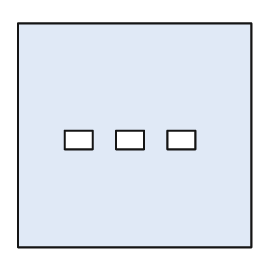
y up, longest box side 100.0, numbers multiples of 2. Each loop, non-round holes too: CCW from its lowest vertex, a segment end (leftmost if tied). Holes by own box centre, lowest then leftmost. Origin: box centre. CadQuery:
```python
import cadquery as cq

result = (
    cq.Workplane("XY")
    .moveTo(-50.0, -48.0)
    .lineTo(50.0, -48.0)
    .lineTo(50.0, 48.0)
    .lineTo(-50.0, 48.0)
    .close()
    .moveTo(-30.0, -6.0)
    .lineTo(-18.0, -6.0)
    .lineTo(-18.0, 2.0)
    .lineTo(-30.0, 2.0)
    .close()
    .moveTo(-8.0, -6.0)
    .lineTo(4.0, -6.0)
    .lineTo(4.0, 2.0)
    .lineTo(-8.0, 2.0)
    .close()
    .moveTo(14.0, -6.0)
    .lineTo(26.0, -6.0)
    .lineTo(26.0, 2.0)
    .lineTo(14.0, 2.0)
    .close()
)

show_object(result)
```